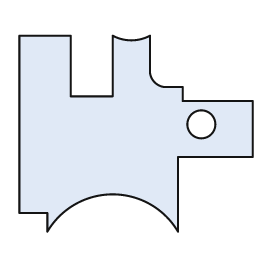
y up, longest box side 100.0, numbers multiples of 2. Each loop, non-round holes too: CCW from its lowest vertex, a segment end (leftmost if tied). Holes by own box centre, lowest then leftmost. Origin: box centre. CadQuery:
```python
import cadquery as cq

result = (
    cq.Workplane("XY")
    .moveTo(-38.0, -42.0)
    .threePointArc((-10.0, -26.0), (18.0, -42.0))
    .lineTo(18.0, -10.0)
    .lineTo(50.0, -10.0)
    .lineTo(50.0, 14.0)
    .lineTo(20.0, 14.0)
    .lineTo(20.0, 20.0)
    .lineTo(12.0, 20.0)
    .threePointArc((8.0, 22.0), (6.0, 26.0))
    .lineTo(6.0, 42.0)
    .threePointArc((-2.0, 40.0), (-10.0, 42.0))
    .lineTo(-10.0, 16.0)
    .lineTo(-28.0, 16.0)
    .lineTo(-28.0, 42.0)
    .lineTo(-50.0, 42.0)
    .lineTo(-50.0, -34.0)
    .lineTo(-38.0, -34.0)
    .close()
    .moveTo(28.0, 4.0)
    .circle(6.0)
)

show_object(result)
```